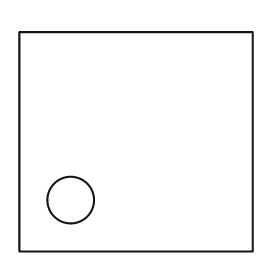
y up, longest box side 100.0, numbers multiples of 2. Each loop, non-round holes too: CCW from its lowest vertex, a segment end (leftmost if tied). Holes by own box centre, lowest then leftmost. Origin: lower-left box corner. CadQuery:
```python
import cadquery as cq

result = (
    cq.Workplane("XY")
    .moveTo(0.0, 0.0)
    .lineTo(100.0, 0.0)
    .lineTo(100.0, 94.0)
    .lineTo(0.0, 94.0)
    .close()
    .moveTo(22.0, 22.0)
    .circle(10.0)
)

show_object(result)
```